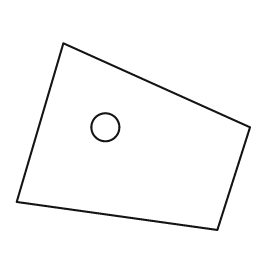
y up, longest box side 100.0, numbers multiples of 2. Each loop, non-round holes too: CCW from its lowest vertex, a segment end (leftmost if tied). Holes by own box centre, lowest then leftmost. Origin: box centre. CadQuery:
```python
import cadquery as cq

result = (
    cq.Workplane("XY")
    .moveTo(36.0, -40.0)
    .lineTo(50.0, 4.0)
    .lineTo(-30.0, 40.0)
    .lineTo(-50.0, -28.0)
    .close()
    .moveTo(-12.0, 4.0)
    .circle(6.0)
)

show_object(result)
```